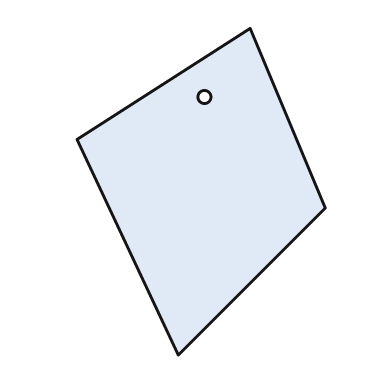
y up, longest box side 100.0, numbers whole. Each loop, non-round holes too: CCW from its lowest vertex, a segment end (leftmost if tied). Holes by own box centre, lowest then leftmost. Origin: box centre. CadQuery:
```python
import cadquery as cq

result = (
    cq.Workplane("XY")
    .moveTo(-7.0, -50.0)
    .lineTo(38.0, -5.0)
    .lineTo(15.0, 50.0)
    .lineTo(-38.0, 16.0)
    .close()
    .moveTo(1.0, 29.0)
    .circle(2.0)
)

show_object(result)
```